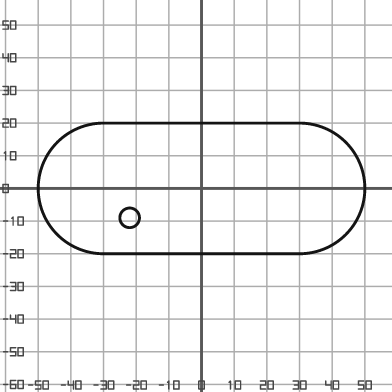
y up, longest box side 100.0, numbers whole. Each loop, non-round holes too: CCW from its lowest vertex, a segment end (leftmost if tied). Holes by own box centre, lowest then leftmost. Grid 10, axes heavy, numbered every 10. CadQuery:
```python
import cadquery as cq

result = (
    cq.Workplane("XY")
    .moveTo(-30.0, -20.0)
    .lineTo(30.0, -20.0)
    .threePointArc((50.0, 0.0), (30.0, 20.0))
    .lineTo(-30.0, 20.0)
    .threePointArc((-50.0, 0.0), (-30.0, -20.0))
    .close()
    .moveTo(-22.0, -9.0)
    .circle(3.0)
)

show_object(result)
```